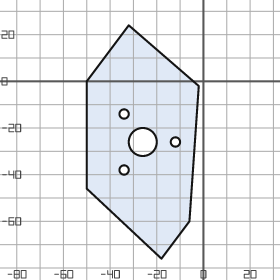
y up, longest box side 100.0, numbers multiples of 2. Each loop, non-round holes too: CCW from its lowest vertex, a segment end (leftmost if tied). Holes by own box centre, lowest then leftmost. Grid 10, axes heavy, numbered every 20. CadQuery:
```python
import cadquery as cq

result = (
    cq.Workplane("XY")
    .moveTo(-18.0, -76.0)
    .lineTo(-6.0, -60.0)
    .lineTo(-2.0, -2.0)
    .lineTo(-32.0, 24.0)
    .lineTo(-50.0, 0.0)
    .lineTo(-50.0, -46.0)
    .close()
    .moveTo(-34.0, -38.0)
    .circle(2.0)
    .moveTo(-26.0, -26.0)
    .circle(6.0)
    .moveTo(-12.0, -26.0)
    .circle(2.0)
    .moveTo(-34.0, -14.0)
    .circle(2.0)
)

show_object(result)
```